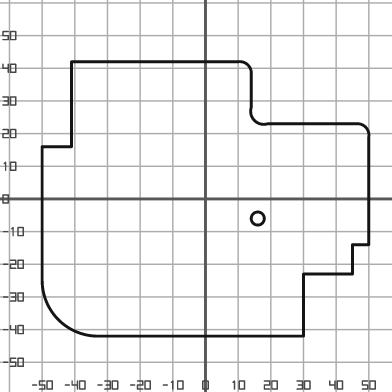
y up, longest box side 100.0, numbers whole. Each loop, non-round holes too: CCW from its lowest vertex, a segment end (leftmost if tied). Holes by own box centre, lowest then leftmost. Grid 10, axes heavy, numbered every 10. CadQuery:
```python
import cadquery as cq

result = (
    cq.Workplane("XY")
    .moveTo(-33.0, -42.0)
    .lineTo(30.0, -42.0)
    .lineTo(30.0, -23.0)
    .lineTo(45.0, -23.0)
    .lineTo(45.0, -14.0)
    .lineTo(50.0, -14.0)
    .lineTo(50.0, 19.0)
    .threePointArc((49.0, 22.0), (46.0, 23.0))
    .lineTo(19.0, 23.0)
    .threePointArc((15.0, 24.0), (14.0, 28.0))
    .lineTo(14.0, 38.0)
    .threePointArc((13.0, 41.0), (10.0, 42.0))
    .lineTo(-41.0, 42.0)
    .lineTo(-41.0, 16.0)
    .lineTo(-50.0, 16.0)
    .lineTo(-50.0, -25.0)
    .threePointArc((-45.0, -37.0), (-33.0, -42.0))
    .close()
    .moveTo(16.0, -6.0)
    .circle(2.0)
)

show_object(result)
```